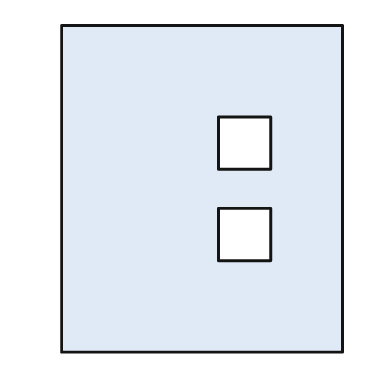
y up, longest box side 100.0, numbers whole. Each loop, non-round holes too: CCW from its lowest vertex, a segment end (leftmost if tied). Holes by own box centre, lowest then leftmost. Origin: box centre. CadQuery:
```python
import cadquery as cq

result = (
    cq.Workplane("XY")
    .moveTo(-43.0, -50.0)
    .lineTo(43.0, -50.0)
    .lineTo(43.0, 50.0)
    .lineTo(-43.0, 50.0)
    .close()
    .moveTo(5.0, -22.0)
    .lineTo(21.0, -22.0)
    .lineTo(21.0, -6.0)
    .lineTo(5.0, -6.0)
    .close()
    .moveTo(5.0, 6.0)
    .lineTo(21.0, 6.0)
    .lineTo(21.0, 22.0)
    .lineTo(5.0, 22.0)
    .close()
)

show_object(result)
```